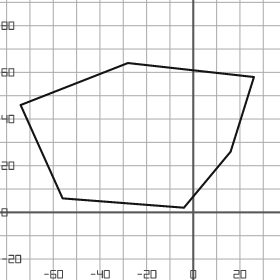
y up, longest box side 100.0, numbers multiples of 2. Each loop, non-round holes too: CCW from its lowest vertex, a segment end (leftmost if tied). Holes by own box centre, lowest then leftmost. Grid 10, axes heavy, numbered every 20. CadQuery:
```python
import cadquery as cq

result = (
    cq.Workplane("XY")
    .moveTo(-4.0, 2.0)
    .lineTo(16.0, 26.0)
    .lineTo(26.0, 58.0)
    .lineTo(-28.0, 64.0)
    .lineTo(-74.0, 46.0)
    .lineTo(-56.0, 6.0)
    .close()
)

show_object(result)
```